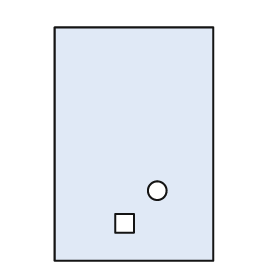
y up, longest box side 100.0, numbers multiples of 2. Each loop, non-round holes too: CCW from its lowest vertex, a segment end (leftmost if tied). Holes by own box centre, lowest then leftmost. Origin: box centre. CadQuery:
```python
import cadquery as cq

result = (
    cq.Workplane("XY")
    .moveTo(-34.0, -50.0)
    .lineTo(34.0, -50.0)
    .lineTo(34.0, 50.0)
    .lineTo(-34.0, 50.0)
    .close()
    .moveTo(-8.0, -38.0)
    .lineTo(0.0, -38.0)
    .lineTo(0.0, -30.0)
    .lineTo(-8.0, -30.0)
    .close()
    .moveTo(10.0, -20.0)
    .circle(4.0)
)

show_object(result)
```